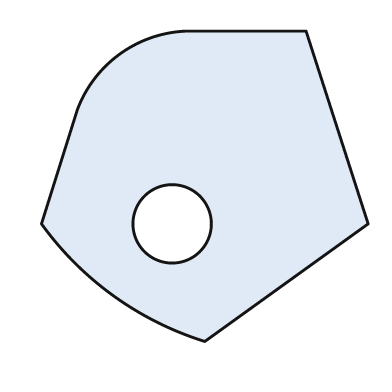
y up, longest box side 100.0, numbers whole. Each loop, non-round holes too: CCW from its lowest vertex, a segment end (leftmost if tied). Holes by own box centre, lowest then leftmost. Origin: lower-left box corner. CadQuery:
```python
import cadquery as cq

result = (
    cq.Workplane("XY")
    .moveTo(50.0, 0.0)
    .lineTo(100.0, 36.0)
    .lineTo(81.0, 95.0)
    .lineTo(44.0, 95.0)
    .threePointArc((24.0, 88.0), (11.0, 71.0))
    .lineTo(0.0, 36.0)
    .threePointArc((22.0, 14.0), (50.0, 0.0))
    .close()
    .moveTo(40.0, 36.0)
    .circle(12.0)
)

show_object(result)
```